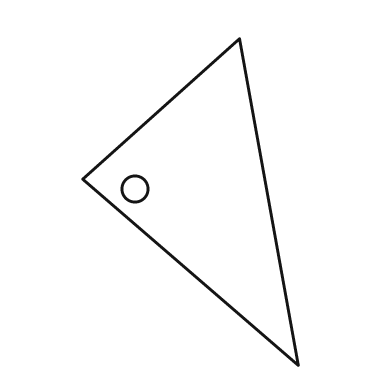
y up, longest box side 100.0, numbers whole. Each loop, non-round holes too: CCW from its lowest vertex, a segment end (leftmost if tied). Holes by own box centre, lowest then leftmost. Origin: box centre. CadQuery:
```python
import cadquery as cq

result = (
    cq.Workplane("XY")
    .moveTo(33.0, -50.0)
    .lineTo(15.0, 50.0)
    .lineTo(-33.0, 7.0)
    .close()
    .moveTo(-17.0, 4.0)
    .circle(4.0)
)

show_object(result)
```